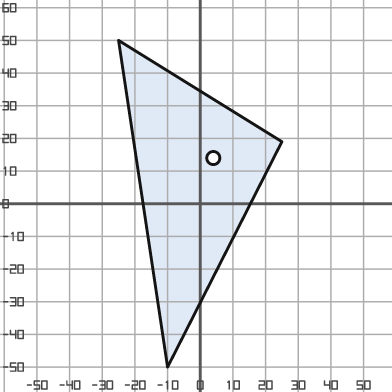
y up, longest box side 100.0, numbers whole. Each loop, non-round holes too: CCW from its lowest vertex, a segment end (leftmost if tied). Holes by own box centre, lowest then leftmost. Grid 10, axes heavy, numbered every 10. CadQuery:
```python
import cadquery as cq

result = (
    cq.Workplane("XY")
    .moveTo(-10.0, -50.0)
    .lineTo(25.0, 19.0)
    .lineTo(-25.0, 50.0)
    .close()
    .moveTo(4.0, 14.0)
    .circle(2.0)
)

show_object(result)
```